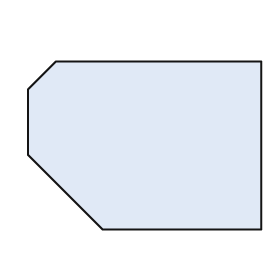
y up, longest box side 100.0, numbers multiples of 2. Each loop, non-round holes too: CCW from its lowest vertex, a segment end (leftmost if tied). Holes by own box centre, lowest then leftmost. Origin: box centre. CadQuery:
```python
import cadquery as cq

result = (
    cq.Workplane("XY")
    .moveTo(-18.0, -36.0)
    .lineTo(50.0, -36.0)
    .lineTo(50.0, 36.0)
    .lineTo(-38.0, 36.0)
    .lineTo(-50.0, 24.0)
    .lineTo(-50.0, -4.0)
    .close()
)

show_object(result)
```